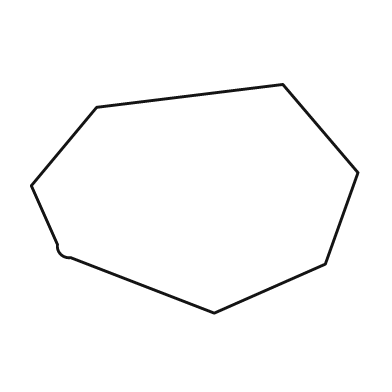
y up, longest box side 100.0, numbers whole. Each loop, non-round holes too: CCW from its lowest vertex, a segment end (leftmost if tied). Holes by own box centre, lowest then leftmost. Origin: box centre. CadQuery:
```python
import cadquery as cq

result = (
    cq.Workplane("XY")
    .moveTo(6.0, -35.0)
    .lineTo(40.0, -20.0)
    .lineTo(50.0, 8.0)
    .lineTo(27.0, 35.0)
    .lineTo(-30.0, 28.0)
    .lineTo(-50.0, 4.0)
    .lineTo(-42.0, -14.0)
    .threePointArc((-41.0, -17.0), (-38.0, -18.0))
    .close()
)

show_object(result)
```